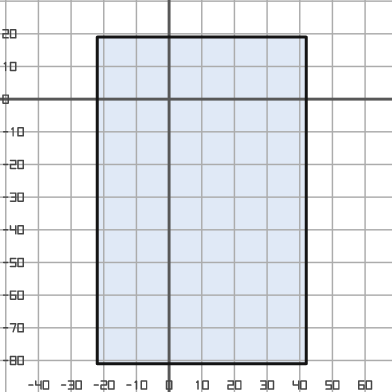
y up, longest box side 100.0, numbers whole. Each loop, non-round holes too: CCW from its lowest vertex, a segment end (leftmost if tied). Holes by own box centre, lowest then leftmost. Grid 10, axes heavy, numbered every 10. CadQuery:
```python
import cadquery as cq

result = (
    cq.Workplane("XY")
    .moveTo(-22.0, -81.0)
    .lineTo(42.0, -81.0)
    .lineTo(42.0, 19.0)
    .lineTo(-22.0, 19.0)
    .close()
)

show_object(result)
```